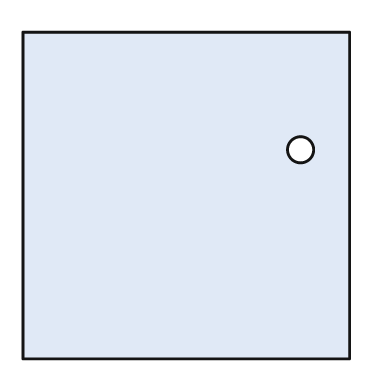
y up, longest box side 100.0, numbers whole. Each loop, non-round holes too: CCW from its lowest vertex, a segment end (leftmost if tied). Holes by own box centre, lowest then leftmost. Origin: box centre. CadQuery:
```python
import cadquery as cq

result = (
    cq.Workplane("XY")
    .moveTo(-50.0, -50.0)
    .lineTo(50.0, -50.0)
    .lineTo(50.0, 50.0)
    .lineTo(-50.0, 50.0)
    .close()
    .moveTo(35.0, 14.0)
    .circle(4.0)
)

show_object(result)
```